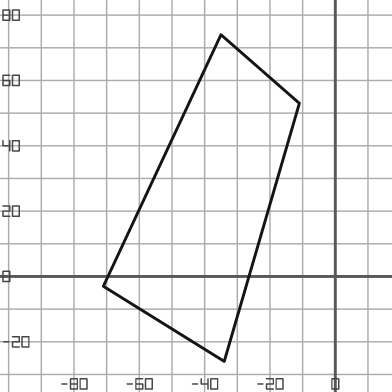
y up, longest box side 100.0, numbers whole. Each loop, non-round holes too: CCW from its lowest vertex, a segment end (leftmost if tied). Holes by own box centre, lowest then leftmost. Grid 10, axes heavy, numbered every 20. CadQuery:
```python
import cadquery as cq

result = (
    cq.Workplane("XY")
    .moveTo(-34.0, -26.0)
    .lineTo(-11.0, 53.0)
    .lineTo(-35.0, 74.0)
    .lineTo(-71.0, -3.0)
    .close()
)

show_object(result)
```